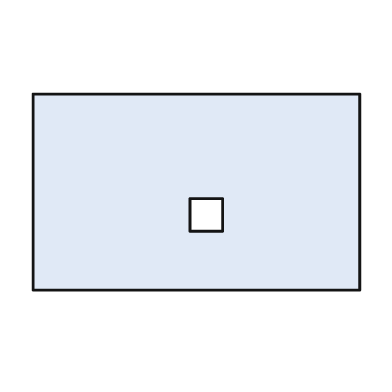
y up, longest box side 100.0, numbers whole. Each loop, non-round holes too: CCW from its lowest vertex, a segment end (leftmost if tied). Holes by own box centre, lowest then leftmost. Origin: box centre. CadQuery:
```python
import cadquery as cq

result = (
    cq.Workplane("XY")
    .moveTo(-50.0, -30.0)
    .lineTo(50.0, -30.0)
    .lineTo(50.0, 30.0)
    .lineTo(-50.0, 30.0)
    .close()
    .moveTo(-2.0, -12.0)
    .lineTo(8.0, -12.0)
    .lineTo(8.0, -2.0)
    .lineTo(-2.0, -2.0)
    .close()
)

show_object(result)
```